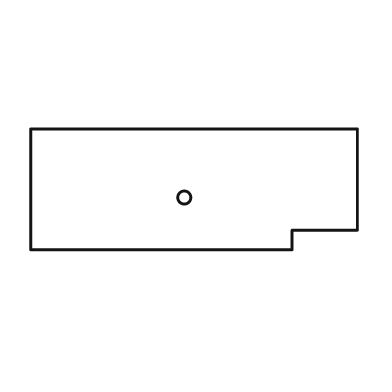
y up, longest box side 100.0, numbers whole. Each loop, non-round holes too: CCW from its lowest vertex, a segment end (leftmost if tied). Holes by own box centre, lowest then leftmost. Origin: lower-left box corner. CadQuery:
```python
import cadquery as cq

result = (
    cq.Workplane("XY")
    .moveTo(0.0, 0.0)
    .lineTo(80.0, 0.0)
    .lineTo(80.0, 6.0)
    .lineTo(100.0, 6.0)
    .lineTo(100.0, 37.0)
    .lineTo(0.0, 37.0)
    .close()
    .moveTo(47.0, 16.0)
    .circle(2.0)
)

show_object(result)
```